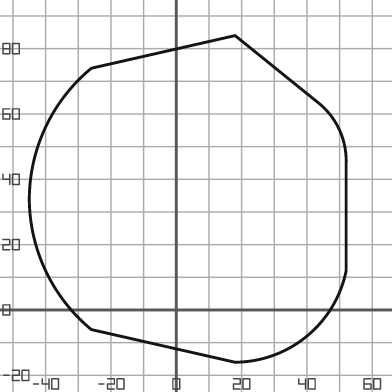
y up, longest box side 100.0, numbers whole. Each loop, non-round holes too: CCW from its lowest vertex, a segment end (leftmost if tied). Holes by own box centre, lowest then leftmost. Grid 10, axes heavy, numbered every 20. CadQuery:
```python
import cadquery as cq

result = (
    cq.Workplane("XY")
    .moveTo(18.0, -16.0)
    .threePointArc((40.0, -8.0), (52.0, 12.0))
    .lineTo(52.0, 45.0)
    .threePointArc((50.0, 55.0), (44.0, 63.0))
    .lineTo(18.0, 84.0)
    .lineTo(-26.0, 74.0)
    .threePointArc((-40.0, 56.0), (-45.0, 34.0))
    .threePointArc((-40.0, 12.0), (-26.0, -6.0))
    .close()
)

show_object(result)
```